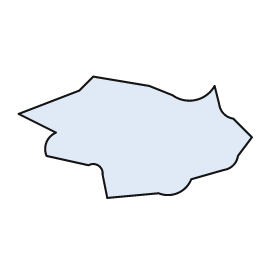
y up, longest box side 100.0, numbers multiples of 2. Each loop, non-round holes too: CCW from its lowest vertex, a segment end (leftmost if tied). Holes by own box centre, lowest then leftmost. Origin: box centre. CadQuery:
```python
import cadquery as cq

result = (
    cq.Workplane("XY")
    .moveTo(-12.0, -26.0)
    .lineTo(10.0, -24.0)
    .threePointArc((18.0, -24.0), (24.0, -18.0))
    .lineTo(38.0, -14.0)
    .threePointArc((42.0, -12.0), (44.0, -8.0))
    .lineTo(50.0, 0.0)
    .lineTo(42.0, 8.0)
    .threePointArc((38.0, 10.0), (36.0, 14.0))
    .lineTo(34.0, 22.0)
    .threePointArc((26.0, 16.0), (16.0, 18.0))
    .lineTo(6.0, 22.0)
    .lineTo(-18.0, 26.0)
    .lineTo(-24.0, 20.0)
    .lineTo(-50.0, 10.0)
    .lineTo(-34.0, 2.0)
    .threePointArc((-38.0, -2.0), (-38.0, -8.0))
    .lineTo(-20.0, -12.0)
    .threePointArc((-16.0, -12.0), (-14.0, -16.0))
    .close()
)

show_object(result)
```